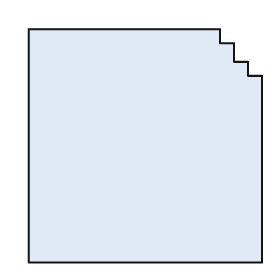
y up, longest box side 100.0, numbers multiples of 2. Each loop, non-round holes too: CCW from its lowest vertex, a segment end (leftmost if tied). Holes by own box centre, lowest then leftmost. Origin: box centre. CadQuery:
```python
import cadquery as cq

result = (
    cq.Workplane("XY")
    .moveTo(-50.0, -50.0)
    .lineTo(50.0, -50.0)
    .lineTo(50.0, 30.0)
    .lineTo(44.0, 30.0)
    .lineTo(44.0, 36.0)
    .lineTo(38.0, 36.0)
    .lineTo(38.0, 44.0)
    .lineTo(32.0, 44.0)
    .lineTo(32.0, 50.0)
    .lineTo(-50.0, 50.0)
    .close()
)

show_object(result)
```